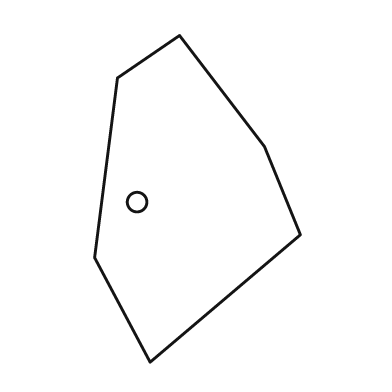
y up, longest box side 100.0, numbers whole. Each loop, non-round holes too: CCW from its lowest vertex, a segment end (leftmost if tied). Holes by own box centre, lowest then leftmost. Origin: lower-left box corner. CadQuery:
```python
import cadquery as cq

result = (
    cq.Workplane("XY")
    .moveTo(17.0, 0.0)
    .lineTo(63.0, 39.0)
    .lineTo(52.0, 66.0)
    .lineTo(26.0, 100.0)
    .lineTo(7.0, 87.0)
    .lineTo(0.0, 32.0)
    .close()
    .moveTo(13.0, 49.0)
    .circle(3.0)
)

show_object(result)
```